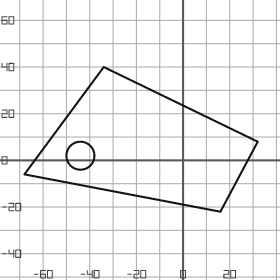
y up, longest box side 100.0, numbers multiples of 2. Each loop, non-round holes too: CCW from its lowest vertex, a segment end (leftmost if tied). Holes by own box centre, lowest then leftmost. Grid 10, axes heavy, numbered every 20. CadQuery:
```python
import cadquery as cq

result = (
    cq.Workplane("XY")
    .moveTo(16.0, -22.0)
    .lineTo(32.0, 8.0)
    .lineTo(-34.0, 40.0)
    .lineTo(-68.0, -6.0)
    .close()
    .moveTo(-44.0, 2.0)
    .circle(6.0)
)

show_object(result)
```